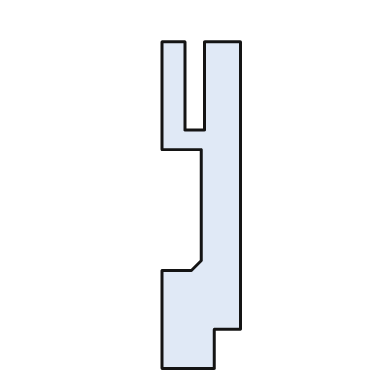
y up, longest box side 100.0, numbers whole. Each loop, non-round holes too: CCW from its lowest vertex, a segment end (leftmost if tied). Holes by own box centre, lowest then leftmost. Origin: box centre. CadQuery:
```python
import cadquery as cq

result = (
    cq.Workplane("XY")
    .moveTo(-12.0, -50.0)
    .lineTo(4.0, -50.0)
    .lineTo(4.0, -38.0)
    .lineTo(12.0, -38.0)
    .lineTo(12.0, 50.0)
    .lineTo(1.0, 50.0)
    .lineTo(1.0, 23.0)
    .lineTo(-5.0, 23.0)
    .lineTo(-5.0, 50.0)
    .lineTo(-12.0, 50.0)
    .lineTo(-12.0, 17.0)
    .lineTo(0.0, 17.0)
    .lineTo(0.0, -17.0)
    .lineTo(-3.0, -20.0)
    .lineTo(-12.0, -20.0)
    .close()
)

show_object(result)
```